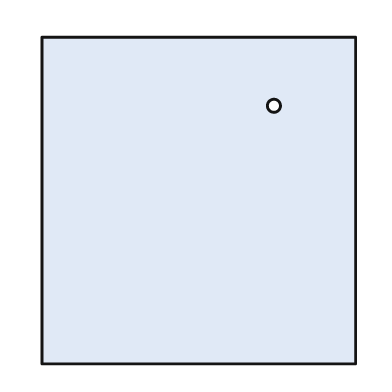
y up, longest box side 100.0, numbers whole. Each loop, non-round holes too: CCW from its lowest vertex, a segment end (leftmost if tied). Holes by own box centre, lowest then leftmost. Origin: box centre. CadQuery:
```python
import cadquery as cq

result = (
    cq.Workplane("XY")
    .moveTo(-48.0, -50.0)
    .lineTo(48.0, -50.0)
    .lineTo(48.0, 50.0)
    .lineTo(-48.0, 50.0)
    .close()
    .moveTo(23.0, 29.0)
    .circle(2.0)
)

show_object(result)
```